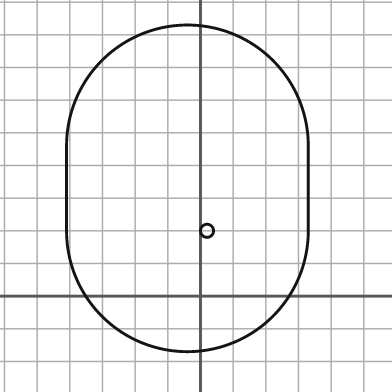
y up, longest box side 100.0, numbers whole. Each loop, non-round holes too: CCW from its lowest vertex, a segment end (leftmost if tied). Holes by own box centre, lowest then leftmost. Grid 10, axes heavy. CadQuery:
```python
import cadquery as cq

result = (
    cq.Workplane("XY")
    .moveTo(-41.0, 20.0)
    .threePointArc((-4.0, -17.0), (33.0, 20.0))
    .lineTo(33.0, 46.0)
    .threePointArc((-4.0, 83.0), (-41.0, 46.0))
    .close()
    .moveTo(2.0, 20.0)
    .circle(2.0)
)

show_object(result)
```